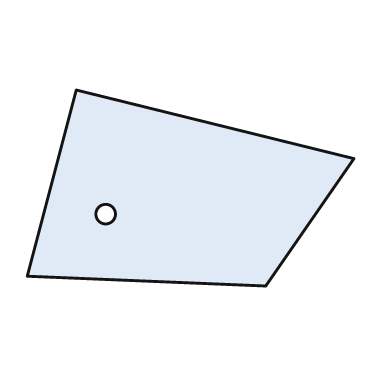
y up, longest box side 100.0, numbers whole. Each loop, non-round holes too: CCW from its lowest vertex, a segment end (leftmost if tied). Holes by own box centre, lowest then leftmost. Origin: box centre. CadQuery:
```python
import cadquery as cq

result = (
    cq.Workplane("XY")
    .moveTo(23.0, -30.0)
    .lineTo(50.0, 9.0)
    .lineTo(-35.0, 30.0)
    .lineTo(-50.0, -27.0)
    .close()
    .moveTo(-26.0, -8.0)
    .circle(3.0)
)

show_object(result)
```